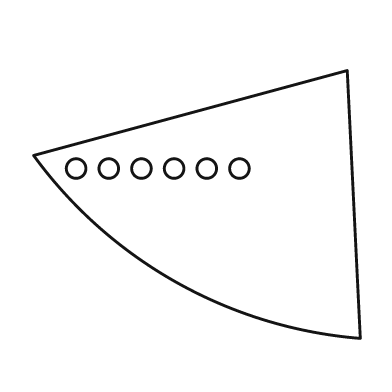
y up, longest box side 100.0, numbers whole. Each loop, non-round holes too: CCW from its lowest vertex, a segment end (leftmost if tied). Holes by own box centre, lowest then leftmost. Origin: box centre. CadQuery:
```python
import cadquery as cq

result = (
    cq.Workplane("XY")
    .moveTo(50.0, -41.0)
    .lineTo(46.0, 41.0)
    .lineTo(-50.0, 15.0)
    .threePointArc((-6.0, -24.0), (50.0, -41.0))
    .close()
    .moveTo(-37.0, 11.0)
    .circle(3.0)
    .moveTo(-27.0, 11.0)
    .circle(3.0)
    .moveTo(-17.0, 11.0)
    .circle(3.0)
    .moveTo(-7.0, 11.0)
    .circle(3.0)
    .moveTo(3.0, 11.0)
    .circle(3.0)
    .moveTo(13.0, 11.0)
    .circle(3.0)
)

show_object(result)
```